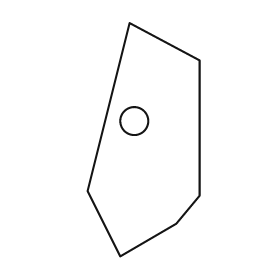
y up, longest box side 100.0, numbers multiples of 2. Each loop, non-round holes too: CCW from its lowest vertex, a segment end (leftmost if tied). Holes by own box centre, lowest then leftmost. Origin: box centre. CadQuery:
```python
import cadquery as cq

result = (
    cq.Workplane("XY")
    .moveTo(-10.0, -50.0)
    .lineTo(14.0, -36.0)
    .lineTo(24.0, -24.0)
    .lineTo(24.0, 34.0)
    .lineTo(-6.0, 50.0)
    .lineTo(-24.0, -22.0)
    .close()
    .moveTo(-4.0, 8.0)
    .circle(6.0)
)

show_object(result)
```